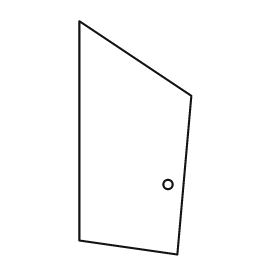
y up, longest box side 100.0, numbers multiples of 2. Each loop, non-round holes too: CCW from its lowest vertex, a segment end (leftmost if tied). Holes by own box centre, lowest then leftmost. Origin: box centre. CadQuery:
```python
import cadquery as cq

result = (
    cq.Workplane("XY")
    .moveTo(18.0, -50.0)
    .lineTo(24.0, 18.0)
    .lineTo(-24.0, 50.0)
    .lineTo(-24.0, -44.0)
    .close()
    .moveTo(14.0, -20.0)
    .circle(2.0)
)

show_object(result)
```